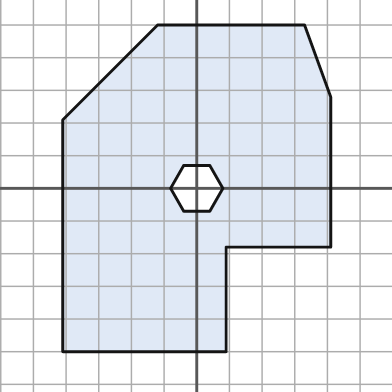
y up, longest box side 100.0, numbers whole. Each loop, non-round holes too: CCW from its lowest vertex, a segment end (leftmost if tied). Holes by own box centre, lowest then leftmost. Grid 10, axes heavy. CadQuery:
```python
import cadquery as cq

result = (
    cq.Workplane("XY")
    .moveTo(-41.0, -50.0)
    .lineTo(9.0, -50.0)
    .lineTo(9.0, -18.0)
    .lineTo(41.0, -18.0)
    .lineTo(41.0, 28.0)
    .lineTo(33.0, 50.0)
    .lineTo(-12.0, 50.0)
    .lineTo(-41.0, 21.0)
    .close()
    .moveTo(-4.0, -7.0)
    .lineTo(4.0, -7.0)
    .lineTo(8.0, 0.0)
    .lineTo(4.0, 7.0)
    .lineTo(-4.0, 7.0)
    .lineTo(-8.0, 0.0)
    .close()
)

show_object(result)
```